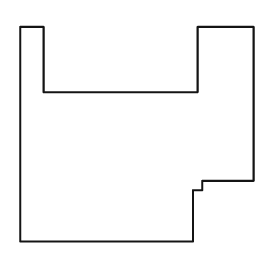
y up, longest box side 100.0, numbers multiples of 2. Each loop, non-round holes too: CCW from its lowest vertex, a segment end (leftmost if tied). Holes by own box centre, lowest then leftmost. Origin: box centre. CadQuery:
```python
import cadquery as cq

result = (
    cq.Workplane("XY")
    .moveTo(-50.0, -46.0)
    .lineTo(24.0, -46.0)
    .lineTo(24.0, -24.0)
    .lineTo(28.0, -24.0)
    .lineTo(28.0, -20.0)
    .lineTo(50.0, -20.0)
    .lineTo(50.0, 46.0)
    .lineTo(26.0, 46.0)
    .lineTo(26.0, 18.0)
    .lineTo(-40.0, 18.0)
    .lineTo(-40.0, 46.0)
    .lineTo(-50.0, 46.0)
    .close()
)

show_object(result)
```